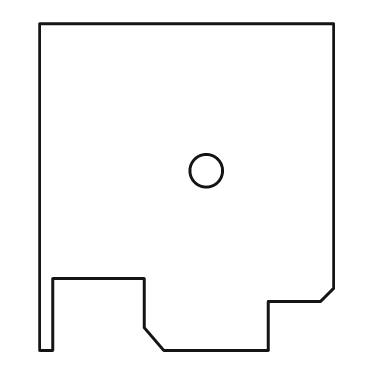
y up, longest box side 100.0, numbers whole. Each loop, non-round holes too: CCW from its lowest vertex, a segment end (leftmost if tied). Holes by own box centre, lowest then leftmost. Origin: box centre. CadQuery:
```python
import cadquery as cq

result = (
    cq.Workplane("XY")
    .moveTo(-45.0, -50.0)
    .lineTo(-41.0, -50.0)
    .lineTo(-41.0, -28.0)
    .lineTo(-13.0, -28.0)
    .lineTo(-13.0, -43.0)
    .lineTo(-7.0, -50.0)
    .lineTo(25.0, -50.0)
    .lineTo(25.0, -35.0)
    .lineTo(41.0, -35.0)
    .lineTo(45.0, -31.0)
    .lineTo(45.0, 50.0)
    .lineTo(-45.0, 50.0)
    .close()
    .moveTo(6.0, 5.0)
    .circle(5.0)
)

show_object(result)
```